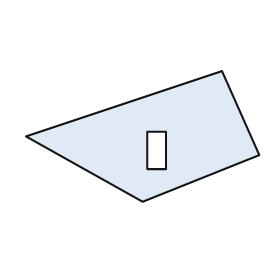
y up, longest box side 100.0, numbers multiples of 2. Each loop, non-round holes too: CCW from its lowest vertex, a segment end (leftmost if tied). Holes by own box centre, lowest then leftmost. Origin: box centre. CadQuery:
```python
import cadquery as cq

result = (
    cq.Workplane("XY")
    .moveTo(0.0, -28.0)
    .lineTo(50.0, -8.0)
    .lineTo(34.0, 28.0)
    .lineTo(-50.0, 0.0)
    .close()
    .moveTo(2.0, -14.0)
    .lineTo(10.0, -14.0)
    .lineTo(10.0, 2.0)
    .lineTo(2.0, 2.0)
    .close()
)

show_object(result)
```